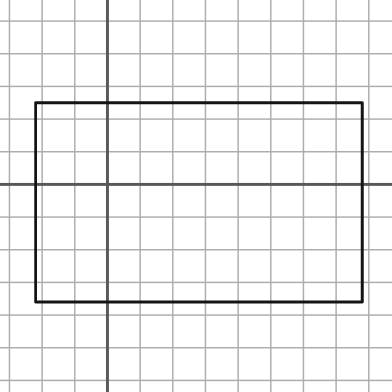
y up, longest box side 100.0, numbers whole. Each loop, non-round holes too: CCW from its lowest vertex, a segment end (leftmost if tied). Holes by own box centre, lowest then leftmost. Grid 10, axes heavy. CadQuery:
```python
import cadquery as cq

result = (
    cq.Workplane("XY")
    .moveTo(-22.0, -36.0)
    .lineTo(78.0, -36.0)
    .lineTo(78.0, 25.0)
    .lineTo(-22.0, 25.0)
    .close()
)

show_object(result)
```